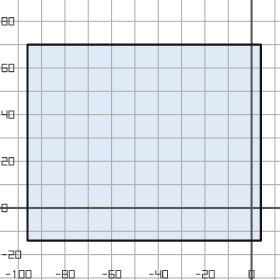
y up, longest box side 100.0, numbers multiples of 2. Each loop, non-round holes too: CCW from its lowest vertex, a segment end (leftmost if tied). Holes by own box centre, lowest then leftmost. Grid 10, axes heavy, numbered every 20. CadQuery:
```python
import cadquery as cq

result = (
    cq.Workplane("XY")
    .moveTo(-96.0, -14.0)
    .lineTo(4.0, -14.0)
    .lineTo(4.0, 70.0)
    .lineTo(-96.0, 70.0)
    .close()
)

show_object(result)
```